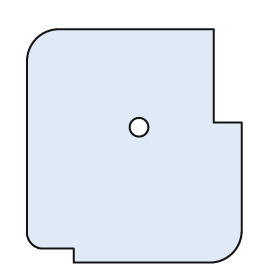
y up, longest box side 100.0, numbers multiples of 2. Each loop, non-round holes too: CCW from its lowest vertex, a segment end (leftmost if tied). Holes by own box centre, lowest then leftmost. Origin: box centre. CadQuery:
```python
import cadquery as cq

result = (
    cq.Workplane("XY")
    .moveTo(-26.0, -50.0)
    .lineTo(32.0, -50.0)
    .threePointArc((42.0, -46.0), (46.0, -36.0))
    .lineTo(46.0, 10.0)
    .lineTo(34.0, 10.0)
    .lineTo(34.0, 50.0)
    .lineTo(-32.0, 50.0)
    .threePointArc((-42.0, 46.0), (-46.0, 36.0))
    .lineTo(-46.0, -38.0)
    .threePointArc((-44.0, -42.0), (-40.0, -44.0))
    .lineTo(-26.0, -44.0)
    .close()
    .moveTo(2.0, 8.0)
    .circle(4.0)
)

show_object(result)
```